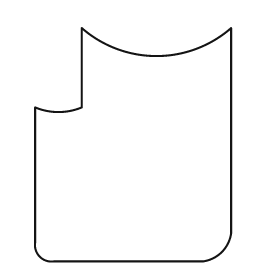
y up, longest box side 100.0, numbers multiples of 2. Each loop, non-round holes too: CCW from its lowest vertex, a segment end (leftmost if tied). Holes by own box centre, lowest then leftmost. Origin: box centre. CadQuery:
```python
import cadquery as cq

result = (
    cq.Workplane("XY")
    .moveTo(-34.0, -50.0)
    .lineTo(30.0, -50.0)
    .threePointArc((38.0, -46.0), (42.0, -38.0))
    .lineTo(42.0, 50.0)
    .threePointArc((10.0, 38.0), (-22.0, 50.0))
    .lineTo(-22.0, 16.0)
    .threePointArc((-32.0, 14.0), (-42.0, 16.0))
    .lineTo(-42.0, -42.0)
    .threePointArc((-40.0, -48.0), (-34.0, -50.0))
    .close()
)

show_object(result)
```